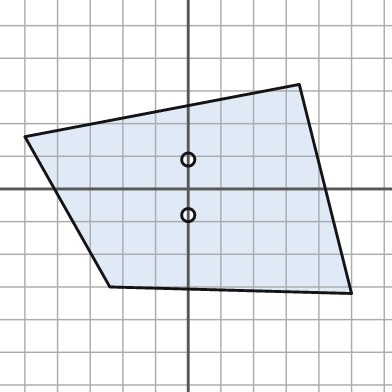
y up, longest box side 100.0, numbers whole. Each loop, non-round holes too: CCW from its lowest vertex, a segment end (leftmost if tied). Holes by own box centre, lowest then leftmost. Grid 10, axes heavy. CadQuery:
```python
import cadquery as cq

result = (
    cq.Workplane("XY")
    .moveTo(50.0, -32.0)
    .lineTo(34.0, 32.0)
    .lineTo(-50.0, 16.0)
    .lineTo(-24.0, -30.0)
    .close()
    .moveTo(0.0, -8.0)
    .circle(2.0)
    .moveTo(0.0, 9.0)
    .circle(2.0)
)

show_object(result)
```